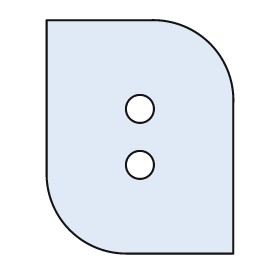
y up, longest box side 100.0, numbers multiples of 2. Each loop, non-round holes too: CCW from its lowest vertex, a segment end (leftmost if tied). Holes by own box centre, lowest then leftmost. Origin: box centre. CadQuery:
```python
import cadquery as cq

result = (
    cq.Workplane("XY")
    .moveTo(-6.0, -50.0)
    .lineTo(40.0, -50.0)
    .lineTo(40.0, 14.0)
    .threePointArc((30.0, 40.0), (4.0, 50.0))
    .lineTo(-40.0, 50.0)
    .lineTo(-40.0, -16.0)
    .threePointArc((-30.0, -40.0), (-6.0, -50.0))
    .close()
    .moveTo(0.0, -12.0)
    .circle(6.0)
    .moveTo(0.0, 12.0)
    .circle(6.0)
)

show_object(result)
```